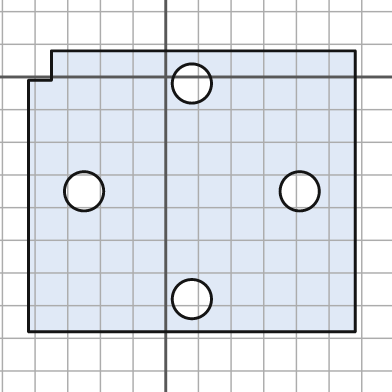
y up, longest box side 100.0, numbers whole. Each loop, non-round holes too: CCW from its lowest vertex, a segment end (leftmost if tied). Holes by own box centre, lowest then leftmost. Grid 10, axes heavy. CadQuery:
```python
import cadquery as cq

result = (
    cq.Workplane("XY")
    .moveTo(-42.0, -78.0)
    .lineTo(58.0, -78.0)
    .lineTo(58.0, 8.0)
    .lineTo(-35.0, 8.0)
    .lineTo(-35.0, -1.0)
    .lineTo(-42.0, -1.0)
    .close()
    .moveTo(8.0, -68.0)
    .circle(6.0)
    .moveTo(-25.0, -35.0)
    .circle(6.0)
    .moveTo(41.0, -35.0)
    .circle(6.0)
    .moveTo(8.0, -2.0)
    .circle(6.0)
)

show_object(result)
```